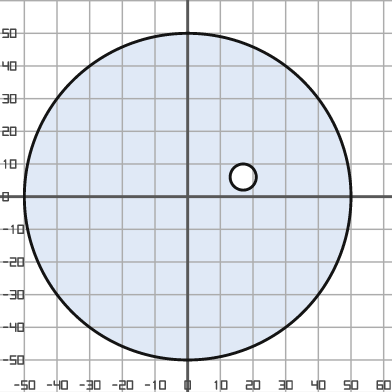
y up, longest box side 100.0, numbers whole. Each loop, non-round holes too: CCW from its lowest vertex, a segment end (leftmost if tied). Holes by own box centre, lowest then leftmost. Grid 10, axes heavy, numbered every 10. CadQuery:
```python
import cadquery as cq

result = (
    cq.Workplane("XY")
    .moveTo(0.0, 0.0)
    .circle(50.0)
    .moveTo(17.0, 6.0)
    .circle(4.0)
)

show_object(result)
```